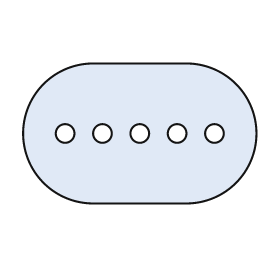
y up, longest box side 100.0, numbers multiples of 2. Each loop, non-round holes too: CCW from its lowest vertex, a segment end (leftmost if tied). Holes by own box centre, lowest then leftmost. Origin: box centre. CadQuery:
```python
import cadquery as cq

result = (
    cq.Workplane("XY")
    .moveTo(-20.0, -30.0)
    .lineTo(20.0, -30.0)
    .threePointArc((50.0, 0.0), (20.0, 30.0))
    .lineTo(-20.0, 30.0)
    .threePointArc((-50.0, 0.0), (-20.0, -30.0))
    .close()
    .moveTo(-32.0, 0.0)
    .circle(4.0)
    .moveTo(-16.0, 0.0)
    .circle(4.0)
    .moveTo(0.0, 0.0)
    .circle(4.0)
    .moveTo(16.0, 0.0)
    .circle(4.0)
    .moveTo(32.0, 0.0)
    .circle(4.0)
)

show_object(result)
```